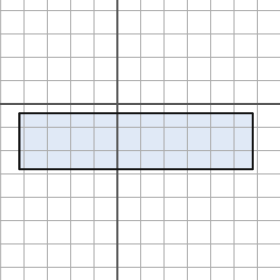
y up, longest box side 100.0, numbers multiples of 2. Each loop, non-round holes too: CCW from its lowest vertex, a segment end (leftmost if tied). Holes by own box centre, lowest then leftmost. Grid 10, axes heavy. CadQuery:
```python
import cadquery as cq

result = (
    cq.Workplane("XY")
    .moveTo(-42.0, -28.0)
    .lineTo(58.0, -28.0)
    .lineTo(58.0, -4.0)
    .lineTo(-42.0, -4.0)
    .close()
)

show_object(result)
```